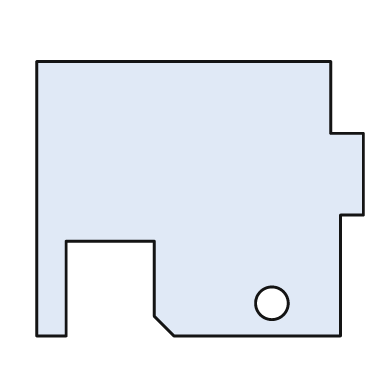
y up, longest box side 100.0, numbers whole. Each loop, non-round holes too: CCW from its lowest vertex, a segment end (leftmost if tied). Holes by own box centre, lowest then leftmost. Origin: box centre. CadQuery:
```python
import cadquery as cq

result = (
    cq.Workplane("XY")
    .moveTo(-50.0, -42.0)
    .lineTo(-41.0, -42.0)
    .lineTo(-41.0, -13.0)
    .lineTo(-14.0, -13.0)
    .lineTo(-14.0, -36.0)
    .lineTo(-8.0, -42.0)
    .lineTo(43.0, -42.0)
    .lineTo(43.0, -5.0)
    .lineTo(50.0, -5.0)
    .lineTo(50.0, 20.0)
    .lineTo(40.0, 20.0)
    .lineTo(40.0, 42.0)
    .lineTo(-50.0, 42.0)
    .close()
    .moveTo(22.0, -32.0)
    .circle(5.0)
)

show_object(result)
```